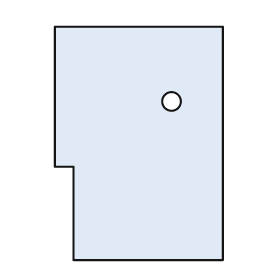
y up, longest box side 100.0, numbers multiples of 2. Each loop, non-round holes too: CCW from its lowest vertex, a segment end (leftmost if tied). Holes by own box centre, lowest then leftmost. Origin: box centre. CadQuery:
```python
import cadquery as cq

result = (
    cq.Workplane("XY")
    .moveTo(-28.0, -50.0)
    .lineTo(36.0, -50.0)
    .lineTo(36.0, 50.0)
    .lineTo(-36.0, 50.0)
    .lineTo(-36.0, -10.0)
    .lineTo(-28.0, -10.0)
    .close()
    .moveTo(14.0, 18.0)
    .circle(4.0)
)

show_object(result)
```